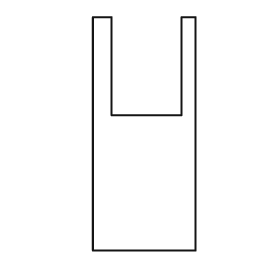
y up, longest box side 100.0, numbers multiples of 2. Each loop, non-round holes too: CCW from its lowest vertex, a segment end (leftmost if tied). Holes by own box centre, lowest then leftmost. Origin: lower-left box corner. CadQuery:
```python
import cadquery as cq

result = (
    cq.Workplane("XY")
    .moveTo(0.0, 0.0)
    .lineTo(44.0, 0.0)
    .lineTo(44.0, 100.0)
    .lineTo(38.0, 100.0)
    .lineTo(38.0, 58.0)
    .lineTo(8.0, 58.0)
    .lineTo(8.0, 100.0)
    .lineTo(0.0, 100.0)
    .close()
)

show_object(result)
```